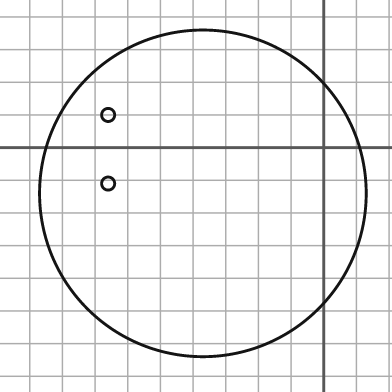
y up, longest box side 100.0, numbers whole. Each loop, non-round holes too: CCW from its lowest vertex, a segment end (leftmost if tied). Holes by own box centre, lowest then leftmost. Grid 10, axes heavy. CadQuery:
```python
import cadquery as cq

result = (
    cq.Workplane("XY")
    .moveTo(-37.0, -14.0)
    .circle(50.0)
    .moveTo(-66.0, -11.0)
    .circle(2.0)
    .moveTo(-66.0, 10.0)
    .circle(2.0)
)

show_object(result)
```